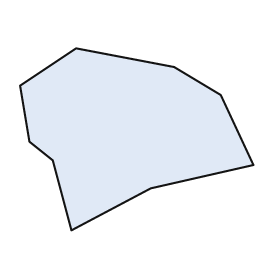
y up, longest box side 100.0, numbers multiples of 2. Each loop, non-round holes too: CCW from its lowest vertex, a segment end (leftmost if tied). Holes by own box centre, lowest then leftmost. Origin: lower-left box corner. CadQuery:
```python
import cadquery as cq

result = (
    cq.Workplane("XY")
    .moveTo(22.0, 0.0)
    .lineTo(56.0, 18.0)
    .lineTo(100.0, 28.0)
    .lineTo(86.0, 58.0)
    .lineTo(66.0, 70.0)
    .lineTo(24.0, 78.0)
    .lineTo(0.0, 62.0)
    .lineTo(4.0, 38.0)
    .lineTo(14.0, 30.0)
    .close()
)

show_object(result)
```